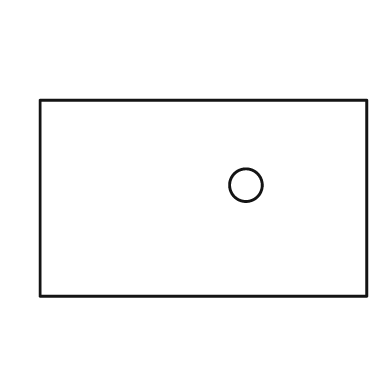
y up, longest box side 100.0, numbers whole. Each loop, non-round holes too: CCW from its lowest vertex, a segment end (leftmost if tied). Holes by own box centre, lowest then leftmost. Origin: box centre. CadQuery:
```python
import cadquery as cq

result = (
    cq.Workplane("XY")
    .moveTo(-50.0, -30.0)
    .lineTo(50.0, -30.0)
    .lineTo(50.0, 30.0)
    .lineTo(-50.0, 30.0)
    .close()
    .moveTo(13.0, 4.0)
    .circle(5.0)
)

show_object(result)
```